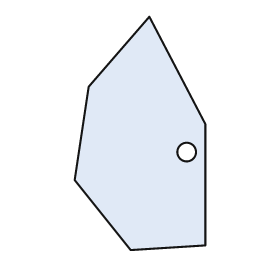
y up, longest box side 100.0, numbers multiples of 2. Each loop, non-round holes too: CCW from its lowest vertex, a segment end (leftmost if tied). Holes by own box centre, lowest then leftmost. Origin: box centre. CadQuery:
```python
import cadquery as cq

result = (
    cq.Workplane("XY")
    .moveTo(-4.0, -50.0)
    .lineTo(28.0, -48.0)
    .lineTo(28.0, 4.0)
    .lineTo(4.0, 50.0)
    .lineTo(-22.0, 20.0)
    .lineTo(-28.0, -20.0)
    .close()
    .moveTo(20.0, -8.0)
    .circle(4.0)
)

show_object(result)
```